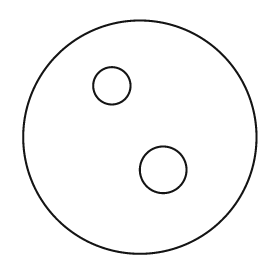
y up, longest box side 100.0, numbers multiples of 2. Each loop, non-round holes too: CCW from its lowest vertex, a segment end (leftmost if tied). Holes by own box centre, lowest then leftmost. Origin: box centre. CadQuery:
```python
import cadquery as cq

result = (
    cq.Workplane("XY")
    .moveTo(0.0, 0.0)
    .circle(50.0)
    .moveTo(10.0, -14.0)
    .circle(10.0)
    .moveTo(-12.0, 22.0)
    .circle(8.0)
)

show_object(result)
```